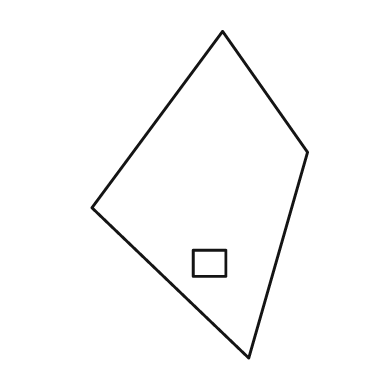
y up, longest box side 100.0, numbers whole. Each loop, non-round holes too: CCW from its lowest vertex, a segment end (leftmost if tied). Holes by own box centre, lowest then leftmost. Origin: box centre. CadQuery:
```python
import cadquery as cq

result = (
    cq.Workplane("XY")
    .moveTo(15.0, -50.0)
    .lineTo(33.0, 13.0)
    .lineTo(7.0, 50.0)
    .lineTo(-33.0, -4.0)
    .close()
    .moveTo(-2.0, -25.0)
    .lineTo(8.0, -25.0)
    .lineTo(8.0, -17.0)
    .lineTo(-2.0, -17.0)
    .close()
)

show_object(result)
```